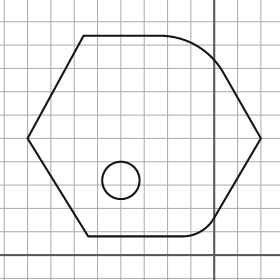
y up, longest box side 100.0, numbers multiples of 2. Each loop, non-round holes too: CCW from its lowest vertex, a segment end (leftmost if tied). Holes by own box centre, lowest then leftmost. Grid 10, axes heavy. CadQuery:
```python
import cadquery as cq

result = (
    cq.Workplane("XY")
    .moveTo(-54.0, 8.0)
    .lineTo(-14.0, 8.0)
    .threePointArc((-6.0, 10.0), (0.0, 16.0))
    .lineTo(20.0, 50.0)
    .lineTo(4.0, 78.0)
    .threePointArc((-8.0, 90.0), (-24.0, 94.0))
    .lineTo(-56.0, 94.0)
    .lineTo(-80.0, 50.0)
    .close()
    .moveTo(-40.0, 32.0)
    .circle(8.0)
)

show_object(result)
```